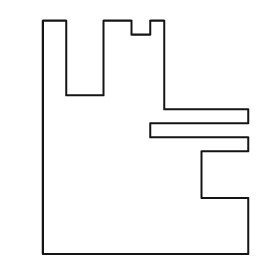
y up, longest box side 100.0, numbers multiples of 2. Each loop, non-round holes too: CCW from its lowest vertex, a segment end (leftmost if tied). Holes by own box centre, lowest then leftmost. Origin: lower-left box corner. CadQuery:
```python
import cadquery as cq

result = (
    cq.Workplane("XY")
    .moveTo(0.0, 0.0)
    .lineTo(88.0, 0.0)
    .lineTo(88.0, 24.0)
    .lineTo(68.0, 24.0)
    .lineTo(68.0, 44.0)
    .lineTo(88.0, 44.0)
    .lineTo(88.0, 50.0)
    .lineTo(46.0, 50.0)
    .lineTo(46.0, 56.0)
    .lineTo(88.0, 56.0)
    .lineTo(88.0, 62.0)
    .lineTo(52.0, 62.0)
    .lineTo(52.0, 100.0)
    .lineTo(46.0, 100.0)
    .lineTo(46.0, 94.0)
    .lineTo(38.0, 94.0)
    .lineTo(38.0, 100.0)
    .lineTo(26.0, 100.0)
    .lineTo(26.0, 68.0)
    .lineTo(10.0, 68.0)
    .lineTo(10.0, 100.0)
    .lineTo(0.0, 100.0)
    .close()
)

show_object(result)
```